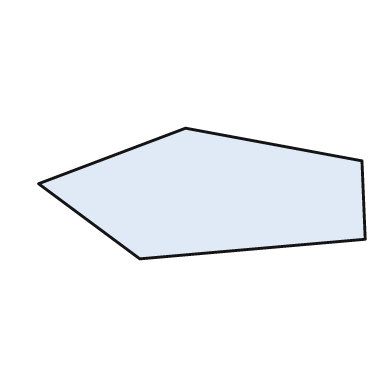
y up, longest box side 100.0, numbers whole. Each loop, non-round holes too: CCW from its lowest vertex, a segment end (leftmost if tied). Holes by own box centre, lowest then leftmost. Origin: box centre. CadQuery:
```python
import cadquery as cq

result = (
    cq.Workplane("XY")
    .moveTo(-19.0, -20.0)
    .lineTo(50.0, -14.0)
    .lineTo(49.0, 10.0)
    .lineTo(-5.0, 20.0)
    .lineTo(-50.0, 3.0)
    .close()
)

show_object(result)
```